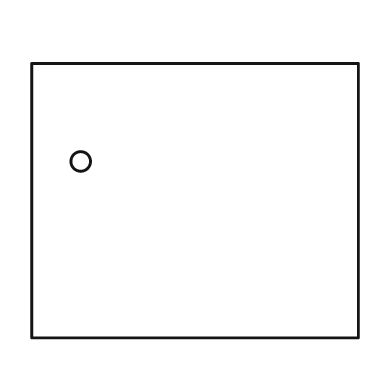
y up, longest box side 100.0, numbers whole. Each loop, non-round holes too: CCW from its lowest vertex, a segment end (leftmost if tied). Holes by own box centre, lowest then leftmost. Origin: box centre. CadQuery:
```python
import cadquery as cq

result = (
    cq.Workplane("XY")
    .moveTo(-50.0, -42.0)
    .lineTo(50.0, -42.0)
    .lineTo(50.0, 42.0)
    .lineTo(-50.0, 42.0)
    .close()
    .moveTo(-35.0, 12.0)
    .circle(3.0)
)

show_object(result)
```